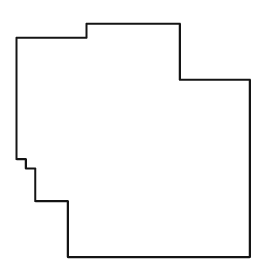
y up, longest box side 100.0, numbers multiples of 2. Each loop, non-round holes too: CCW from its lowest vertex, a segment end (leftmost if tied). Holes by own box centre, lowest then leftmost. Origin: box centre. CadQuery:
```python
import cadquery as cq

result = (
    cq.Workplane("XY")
    .moveTo(-28.0, -50.0)
    .lineTo(50.0, -50.0)
    .lineTo(50.0, 26.0)
    .lineTo(20.0, 26.0)
    .lineTo(20.0, 50.0)
    .lineTo(-20.0, 50.0)
    .lineTo(-20.0, 44.0)
    .lineTo(-50.0, 44.0)
    .lineTo(-50.0, -8.0)
    .lineTo(-46.0, -8.0)
    .lineTo(-46.0, -12.0)
    .lineTo(-42.0, -12.0)
    .lineTo(-42.0, -26.0)
    .lineTo(-28.0, -26.0)
    .close()
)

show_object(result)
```